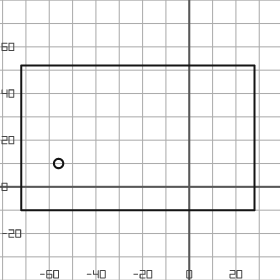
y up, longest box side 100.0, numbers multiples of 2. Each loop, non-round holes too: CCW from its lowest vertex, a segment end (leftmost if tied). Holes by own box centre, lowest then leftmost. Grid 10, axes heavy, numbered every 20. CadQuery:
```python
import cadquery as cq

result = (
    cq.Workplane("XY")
    .moveTo(-72.0, -10.0)
    .lineTo(28.0, -10.0)
    .lineTo(28.0, 52.0)
    .lineTo(-72.0, 52.0)
    .close()
    .moveTo(-56.0, 10.0)
    .circle(2.0)
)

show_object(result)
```